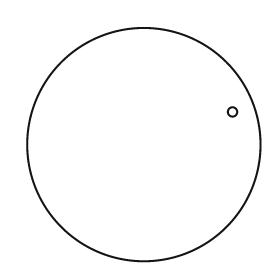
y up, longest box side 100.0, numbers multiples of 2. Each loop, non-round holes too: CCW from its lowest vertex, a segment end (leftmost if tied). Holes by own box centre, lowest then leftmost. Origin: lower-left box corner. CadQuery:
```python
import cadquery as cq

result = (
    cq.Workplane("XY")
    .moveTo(50.0, 50.0)
    .circle(50.0)
    .moveTo(88.0, 64.0)
    .circle(2.0)
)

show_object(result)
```